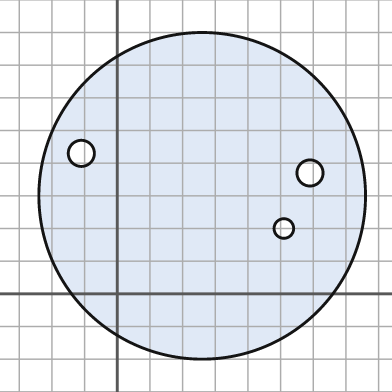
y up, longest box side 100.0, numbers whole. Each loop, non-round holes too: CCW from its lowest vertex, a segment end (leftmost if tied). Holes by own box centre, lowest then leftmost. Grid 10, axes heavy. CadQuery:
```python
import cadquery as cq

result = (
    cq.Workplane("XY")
    .moveTo(26.0, 30.0)
    .circle(50.0)
    .moveTo(51.0, 20.0)
    .circle(3.0)
    .moveTo(59.0, 37.0)
    .circle(4.0)
    .moveTo(-11.0, 43.0)
    .circle(4.0)
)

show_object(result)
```